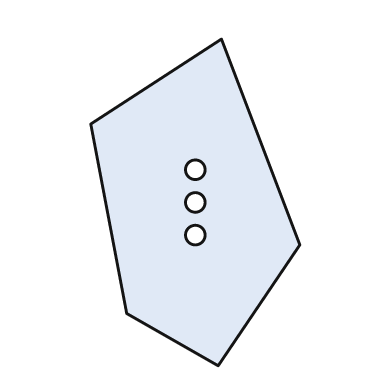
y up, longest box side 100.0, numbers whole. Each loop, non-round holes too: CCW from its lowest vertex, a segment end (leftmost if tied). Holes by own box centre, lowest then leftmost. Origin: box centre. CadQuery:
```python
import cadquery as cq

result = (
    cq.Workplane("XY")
    .moveTo(7.0, -50.0)
    .lineTo(32.0, -13.0)
    .lineTo(8.0, 50.0)
    .lineTo(-32.0, 24.0)
    .lineTo(-21.0, -34.0)
    .close()
    .moveTo(0.0, -10.0)
    .circle(3.0)
    .moveTo(0.0, 0.0)
    .circle(3.0)
    .moveTo(0.0, 10.0)
    .circle(3.0)
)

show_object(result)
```